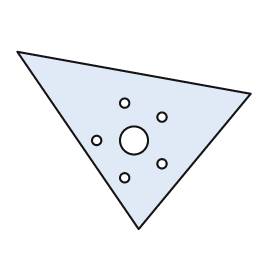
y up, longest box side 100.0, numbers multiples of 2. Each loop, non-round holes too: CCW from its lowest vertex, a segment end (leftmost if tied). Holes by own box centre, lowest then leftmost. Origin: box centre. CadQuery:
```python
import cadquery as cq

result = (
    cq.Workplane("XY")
    .moveTo(2.0, -38.0)
    .lineTo(50.0, 20.0)
    .lineTo(-50.0, 38.0)
    .close()
    .moveTo(-4.0, -16.0)
    .circle(2.0)
    .moveTo(12.0, -10.0)
    .circle(2.0)
    .moveTo(-16.0, 0.0)
    .circle(2.0)
    .moveTo(0.0, 0.0)
    .circle(6.0)
    .moveTo(12.0, 10.0)
    .circle(2.0)
    .moveTo(-4.0, 16.0)
    .circle(2.0)
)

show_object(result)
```